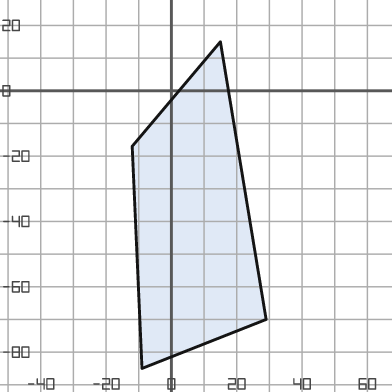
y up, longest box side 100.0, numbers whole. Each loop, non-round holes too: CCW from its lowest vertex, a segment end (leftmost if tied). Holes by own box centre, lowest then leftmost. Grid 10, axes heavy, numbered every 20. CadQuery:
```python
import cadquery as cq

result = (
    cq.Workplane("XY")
    .moveTo(-9.0, -85.0)
    .lineTo(29.0, -70.0)
    .lineTo(15.0, 15.0)
    .lineTo(-12.0, -17.0)
    .close()
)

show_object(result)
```